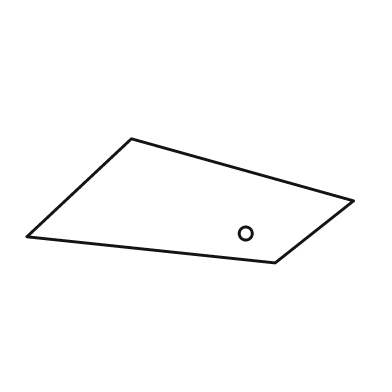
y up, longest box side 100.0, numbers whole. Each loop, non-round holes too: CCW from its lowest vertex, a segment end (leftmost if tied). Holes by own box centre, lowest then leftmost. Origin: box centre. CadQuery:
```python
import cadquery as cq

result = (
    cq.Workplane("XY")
    .moveTo(26.0, -19.0)
    .lineTo(50.0, 0.0)
    .lineTo(-18.0, 19.0)
    .lineTo(-50.0, -11.0)
    .close()
    .moveTo(17.0, -10.0)
    .circle(2.0)
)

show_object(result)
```